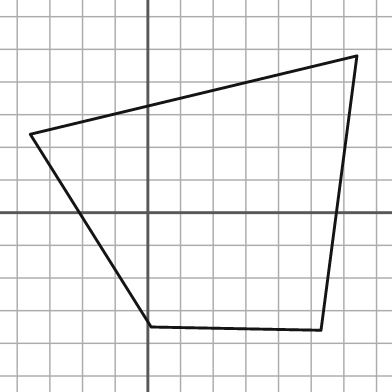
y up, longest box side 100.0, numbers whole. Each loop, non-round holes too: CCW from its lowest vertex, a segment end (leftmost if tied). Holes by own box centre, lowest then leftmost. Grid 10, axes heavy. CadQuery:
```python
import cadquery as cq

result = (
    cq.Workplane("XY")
    .moveTo(53.0, -36.0)
    .lineTo(64.0, 48.0)
    .lineTo(-36.0, 24.0)
    .lineTo(1.0, -35.0)
    .close()
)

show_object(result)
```